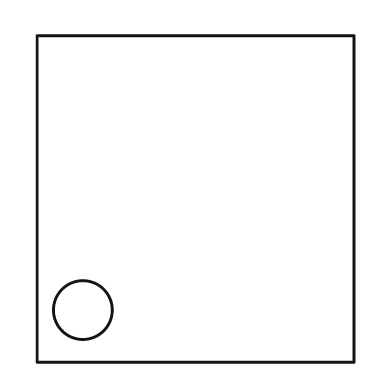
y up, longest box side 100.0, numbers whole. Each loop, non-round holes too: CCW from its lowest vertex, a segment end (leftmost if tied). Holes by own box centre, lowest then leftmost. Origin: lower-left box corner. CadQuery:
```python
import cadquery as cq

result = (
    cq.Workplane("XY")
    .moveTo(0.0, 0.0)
    .lineTo(97.0, 0.0)
    .lineTo(97.0, 100.0)
    .lineTo(0.0, 100.0)
    .close()
    .moveTo(14.0, 16.0)
    .circle(9.0)
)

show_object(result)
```